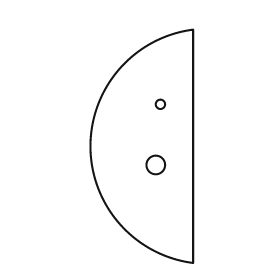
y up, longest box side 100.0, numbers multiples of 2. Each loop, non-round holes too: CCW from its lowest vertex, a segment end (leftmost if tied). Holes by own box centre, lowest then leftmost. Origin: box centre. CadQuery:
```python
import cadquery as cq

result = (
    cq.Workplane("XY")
    .moveTo(22.0, -50.0)
    .lineTo(22.0, 50.0)
    .threePointArc((-22.0, 0.0), (22.0, -50.0))
    .close()
    .moveTo(6.0, -8.0)
    .circle(4.0)
    .moveTo(8.0, 18.0)
    .circle(2.0)
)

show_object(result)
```